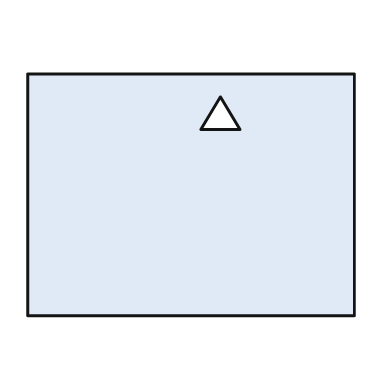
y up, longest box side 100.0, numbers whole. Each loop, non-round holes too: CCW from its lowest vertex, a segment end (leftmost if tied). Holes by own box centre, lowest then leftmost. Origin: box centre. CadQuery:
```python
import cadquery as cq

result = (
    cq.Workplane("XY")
    .moveTo(-50.0, -37.0)
    .lineTo(50.0, -37.0)
    .lineTo(50.0, 37.0)
    .lineTo(-50.0, 37.0)
    .close()
    .moveTo(3.0, 20.0)
    .lineTo(15.0, 20.0)
    .lineTo(9.0, 30.0)
    .close()
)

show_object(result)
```